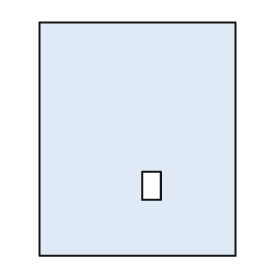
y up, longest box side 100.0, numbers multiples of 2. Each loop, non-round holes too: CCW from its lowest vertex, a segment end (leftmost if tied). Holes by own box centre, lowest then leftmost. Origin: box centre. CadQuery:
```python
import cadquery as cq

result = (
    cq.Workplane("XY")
    .moveTo(-42.0, -50.0)
    .lineTo(42.0, -50.0)
    .lineTo(42.0, 50.0)
    .lineTo(-42.0, 50.0)
    .close()
    .moveTo(2.0, -26.0)
    .lineTo(10.0, -26.0)
    .lineTo(10.0, -14.0)
    .lineTo(2.0, -14.0)
    .close()
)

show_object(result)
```